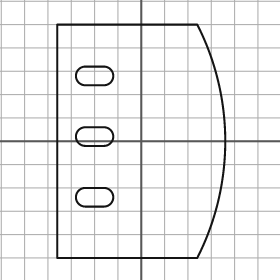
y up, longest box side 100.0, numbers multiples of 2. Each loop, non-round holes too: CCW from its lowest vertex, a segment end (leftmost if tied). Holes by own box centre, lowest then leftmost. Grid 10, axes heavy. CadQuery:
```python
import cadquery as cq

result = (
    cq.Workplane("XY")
    .moveTo(-36.0, -50.0)
    .lineTo(24.0, -50.0)
    .threePointArc((36.0, 0.0), (24.0, 50.0))
    .lineTo(-36.0, 50.0)
    .close()
    .moveTo(-24.0, -28.0)
    .lineTo(-16.0, -28.0)
    .threePointArc((-12.0, -24.0), (-16.0, -20.0))
    .lineTo(-24.0, -20.0)
    .threePointArc((-28.0, -24.0), (-24.0, -28.0))
    .close()
    .moveTo(-24.0, -2.0)
    .lineTo(-16.0, -2.0)
    .threePointArc((-12.0, 2.0), (-16.0, 6.0))
    .lineTo(-24.0, 6.0)
    .threePointArc((-28.0, 2.0), (-24.0, -2.0))
    .close()
    .moveTo(-24.0, 24.0)
    .lineTo(-16.0, 24.0)
    .threePointArc((-12.0, 28.0), (-16.0, 32.0))
    .lineTo(-24.0, 32.0)
    .threePointArc((-28.0, 28.0), (-24.0, 24.0))
    .close()
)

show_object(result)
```